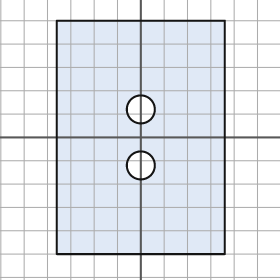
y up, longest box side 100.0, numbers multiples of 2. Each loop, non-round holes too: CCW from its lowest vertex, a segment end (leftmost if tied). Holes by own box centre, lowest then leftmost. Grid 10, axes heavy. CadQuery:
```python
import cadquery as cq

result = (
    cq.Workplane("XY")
    .moveTo(-36.0, -50.0)
    .lineTo(36.0, -50.0)
    .lineTo(36.0, 50.0)
    .lineTo(-36.0, 50.0)
    .close()
    .moveTo(0.0, -12.0)
    .circle(6.0)
    .moveTo(0.0, 12.0)
    .circle(6.0)
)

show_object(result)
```